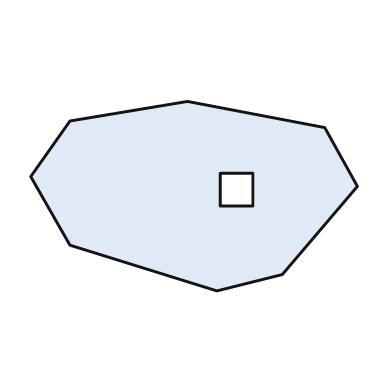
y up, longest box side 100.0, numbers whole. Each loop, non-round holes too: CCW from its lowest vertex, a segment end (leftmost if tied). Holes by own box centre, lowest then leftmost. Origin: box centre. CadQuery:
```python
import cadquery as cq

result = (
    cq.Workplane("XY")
    .moveTo(7.0, -29.0)
    .lineTo(27.0, -24.0)
    .lineTo(50.0, 3.0)
    .lineTo(40.0, 21.0)
    .lineTo(-2.0, 29.0)
    .lineTo(-38.0, 23.0)
    .lineTo(-50.0, 6.0)
    .lineTo(-38.0, -15.0)
    .close()
    .moveTo(8.0, -3.0)
    .lineTo(18.0, -3.0)
    .lineTo(18.0, 7.0)
    .lineTo(8.0, 7.0)
    .close()
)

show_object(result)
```